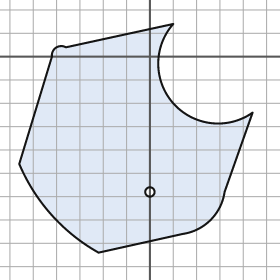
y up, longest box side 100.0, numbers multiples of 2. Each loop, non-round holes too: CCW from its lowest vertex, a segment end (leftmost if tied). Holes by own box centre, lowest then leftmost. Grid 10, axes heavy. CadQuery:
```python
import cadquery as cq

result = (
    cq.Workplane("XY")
    .moveTo(-22.0, -84.0)
    .lineTo(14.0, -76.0)
    .threePointArc((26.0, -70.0), (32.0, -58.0))
    .lineTo(44.0, -24.0)
    .threePointArc((10.0, -20.0), (10.0, 14.0))
    .lineTo(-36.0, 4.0)
    .threePointArc((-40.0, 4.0), (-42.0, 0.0))
    .lineTo(-56.0, -46.0)
    .threePointArc((-42.0, -68.0), (-22.0, -84.0))
    .close()
    .moveTo(0.0, -58.0)
    .circle(2.0)
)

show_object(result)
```